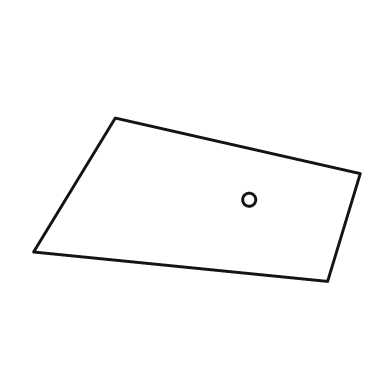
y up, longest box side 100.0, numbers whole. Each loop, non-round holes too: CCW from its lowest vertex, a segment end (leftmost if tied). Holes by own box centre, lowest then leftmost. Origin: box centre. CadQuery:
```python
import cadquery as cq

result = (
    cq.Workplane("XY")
    .moveTo(40.0, -25.0)
    .lineTo(50.0, 8.0)
    .lineTo(-25.0, 25.0)
    .lineTo(-50.0, -16.0)
    .close()
    .moveTo(16.0, 0.0)
    .circle(2.0)
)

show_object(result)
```